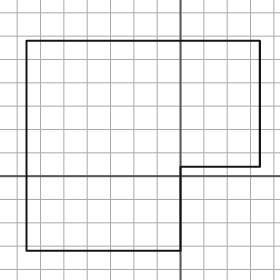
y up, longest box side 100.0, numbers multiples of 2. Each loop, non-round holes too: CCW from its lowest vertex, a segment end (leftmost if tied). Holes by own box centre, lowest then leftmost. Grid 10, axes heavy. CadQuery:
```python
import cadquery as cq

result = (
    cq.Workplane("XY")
    .moveTo(-66.0, -32.0)
    .lineTo(0.0, -32.0)
    .lineTo(0.0, 4.0)
    .lineTo(34.0, 4.0)
    .lineTo(34.0, 58.0)
    .lineTo(-66.0, 58.0)
    .close()
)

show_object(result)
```